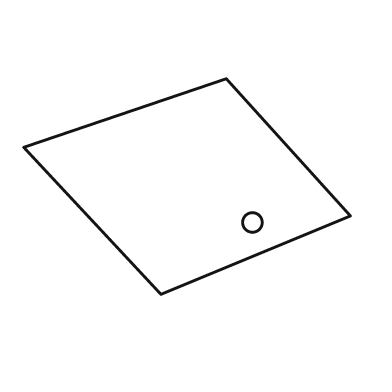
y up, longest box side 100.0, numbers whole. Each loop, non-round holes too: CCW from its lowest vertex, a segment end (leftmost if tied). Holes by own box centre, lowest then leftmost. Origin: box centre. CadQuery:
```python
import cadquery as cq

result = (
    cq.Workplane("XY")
    .moveTo(-8.0, -33.0)
    .lineTo(50.0, -9.0)
    .lineTo(12.0, 33.0)
    .lineTo(-50.0, 12.0)
    .close()
    .moveTo(20.0, -11.0)
    .circle(3.0)
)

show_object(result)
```